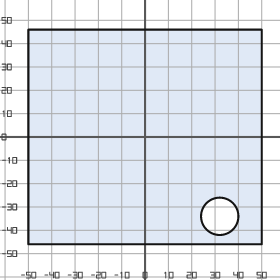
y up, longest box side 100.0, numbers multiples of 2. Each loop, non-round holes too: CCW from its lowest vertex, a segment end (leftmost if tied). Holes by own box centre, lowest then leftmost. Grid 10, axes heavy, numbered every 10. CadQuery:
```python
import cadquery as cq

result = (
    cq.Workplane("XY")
    .moveTo(-50.0, -46.0)
    .lineTo(50.0, -46.0)
    .lineTo(50.0, 46.0)
    .lineTo(-50.0, 46.0)
    .close()
    .moveTo(32.0, -34.0)
    .circle(8.0)
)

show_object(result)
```